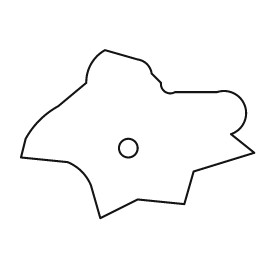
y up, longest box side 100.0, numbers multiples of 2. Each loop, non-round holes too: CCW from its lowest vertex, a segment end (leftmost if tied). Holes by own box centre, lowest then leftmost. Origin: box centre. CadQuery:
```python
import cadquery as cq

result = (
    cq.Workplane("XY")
    .moveTo(-16.0, -36.0)
    .lineTo(0.0, -28.0)
    .lineTo(20.0, -30.0)
    .lineTo(24.0, -16.0)
    .lineTo(50.0, -8.0)
    .lineTo(40.0, 0.0)
    .threePointArc((46.0, 12.0), (34.0, 18.0))
    .lineTo(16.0, 18.0)
    .threePointArc((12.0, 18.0), (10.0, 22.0))
    .lineTo(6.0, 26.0)
    .threePointArc((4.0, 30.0), (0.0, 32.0))
    .lineTo(-14.0, 36.0)
    .threePointArc((-20.0, 30.0), (-22.0, 22.0))
    .lineTo(-34.0, 12.0)
    .threePointArc((-42.0, 6.0), (-48.0, -2.0))
    .lineTo(-50.0, -10.0)
    .lineTo(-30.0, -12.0)
    .threePointArc((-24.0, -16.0), (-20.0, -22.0))
    .close()
    .moveTo(-4.0, -6.0)
    .circle(4.0)
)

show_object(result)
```